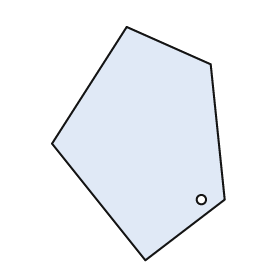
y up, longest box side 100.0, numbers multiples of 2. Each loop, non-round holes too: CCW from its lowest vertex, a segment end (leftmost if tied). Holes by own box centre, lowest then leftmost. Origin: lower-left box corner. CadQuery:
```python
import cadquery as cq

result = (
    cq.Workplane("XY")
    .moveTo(40.0, 0.0)
    .lineTo(74.0, 26.0)
    .lineTo(68.0, 84.0)
    .lineTo(32.0, 100.0)
    .lineTo(0.0, 50.0)
    .close()
    .moveTo(64.0, 26.0)
    .circle(2.0)
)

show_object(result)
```